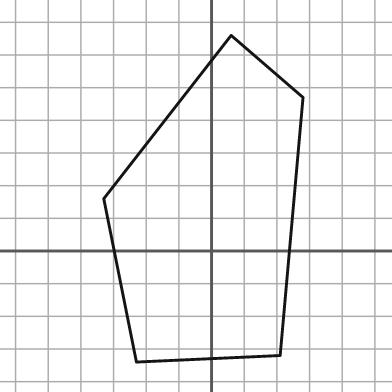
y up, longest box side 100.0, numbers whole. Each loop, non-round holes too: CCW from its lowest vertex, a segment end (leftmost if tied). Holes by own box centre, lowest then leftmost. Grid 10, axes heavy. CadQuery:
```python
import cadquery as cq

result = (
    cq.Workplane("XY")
    .moveTo(-23.0, -34.0)
    .lineTo(21.0, -32.0)
    .lineTo(28.0, 47.0)
    .lineTo(6.0, 66.0)
    .lineTo(-33.0, 16.0)
    .close()
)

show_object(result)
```